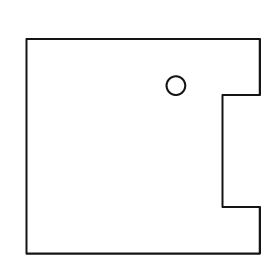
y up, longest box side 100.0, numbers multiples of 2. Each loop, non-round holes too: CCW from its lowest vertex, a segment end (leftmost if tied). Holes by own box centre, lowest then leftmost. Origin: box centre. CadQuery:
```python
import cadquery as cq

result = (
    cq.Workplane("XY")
    .moveTo(-50.0, -46.0)
    .lineTo(50.0, -46.0)
    .lineTo(50.0, -26.0)
    .lineTo(34.0, -26.0)
    .lineTo(34.0, 22.0)
    .lineTo(50.0, 22.0)
    .lineTo(50.0, 46.0)
    .lineTo(-50.0, 46.0)
    .close()
    .moveTo(14.0, 26.0)
    .circle(4.0)
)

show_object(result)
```